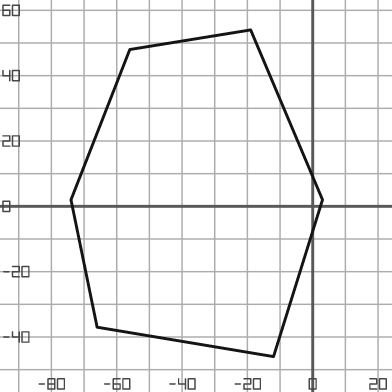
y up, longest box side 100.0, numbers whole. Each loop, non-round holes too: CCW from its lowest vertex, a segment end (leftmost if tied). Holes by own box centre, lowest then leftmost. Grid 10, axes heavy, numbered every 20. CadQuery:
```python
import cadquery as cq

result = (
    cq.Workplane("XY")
    .moveTo(-12.0, -46.0)
    .lineTo(3.0, 2.0)
    .lineTo(-19.0, 54.0)
    .lineTo(-56.0, 48.0)
    .lineTo(-74.0, 2.0)
    .lineTo(-66.0, -37.0)
    .close()
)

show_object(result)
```